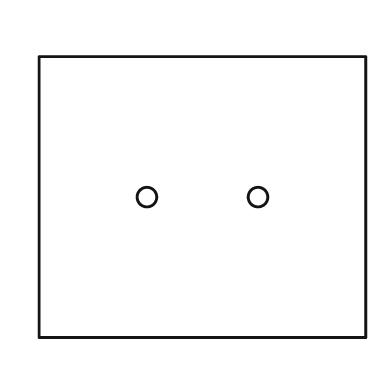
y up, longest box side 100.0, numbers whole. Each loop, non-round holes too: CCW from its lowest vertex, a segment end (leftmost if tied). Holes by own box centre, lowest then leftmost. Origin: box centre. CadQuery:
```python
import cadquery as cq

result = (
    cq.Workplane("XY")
    .moveTo(-50.0, -43.0)
    .lineTo(50.0, -43.0)
    .lineTo(50.0, 43.0)
    .lineTo(-50.0, 43.0)
    .close()
    .moveTo(-17.0, 0.0)
    .circle(3.0)
    .moveTo(17.0, 0.0)
    .circle(3.0)
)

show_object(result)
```